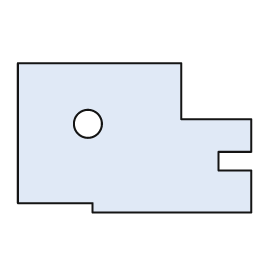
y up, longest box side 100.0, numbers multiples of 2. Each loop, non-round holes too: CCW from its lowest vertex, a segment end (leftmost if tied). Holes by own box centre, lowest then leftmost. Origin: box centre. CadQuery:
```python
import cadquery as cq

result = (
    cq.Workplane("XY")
    .moveTo(-18.0, -32.0)
    .lineTo(50.0, -32.0)
    .lineTo(50.0, -14.0)
    .lineTo(36.0, -14.0)
    .lineTo(36.0, -6.0)
    .lineTo(50.0, -6.0)
    .lineTo(50.0, 8.0)
    .lineTo(20.0, 8.0)
    .lineTo(20.0, 32.0)
    .lineTo(-50.0, 32.0)
    .lineTo(-50.0, -28.0)
    .lineTo(-18.0, -28.0)
    .close()
    .moveTo(-20.0, 6.0)
    .circle(6.0)
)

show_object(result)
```